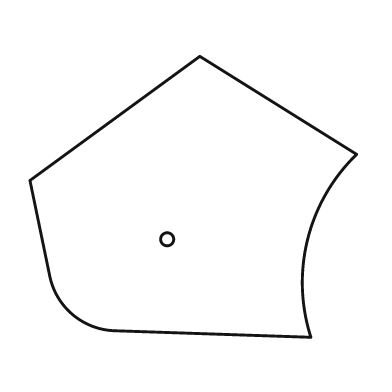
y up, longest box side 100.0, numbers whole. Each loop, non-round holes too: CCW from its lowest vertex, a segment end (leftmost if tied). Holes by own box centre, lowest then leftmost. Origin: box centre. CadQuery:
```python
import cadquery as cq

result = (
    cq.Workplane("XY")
    .moveTo(36.0, -43.0)
    .threePointArc((35.0, -13.0), (50.0, 13.0))
    .lineTo(2.0, 43.0)
    .lineTo(-50.0, 5.0)
    .lineTo(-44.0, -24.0)
    .threePointArc((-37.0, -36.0), (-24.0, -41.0))
    .close()
    .moveTo(-8.0, -13.0)
    .circle(2.0)
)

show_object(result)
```